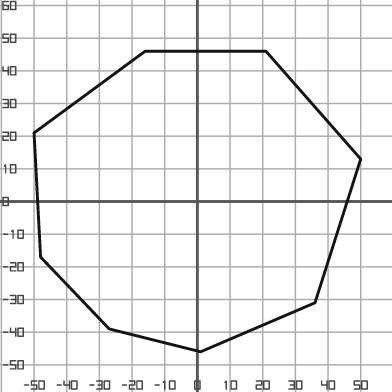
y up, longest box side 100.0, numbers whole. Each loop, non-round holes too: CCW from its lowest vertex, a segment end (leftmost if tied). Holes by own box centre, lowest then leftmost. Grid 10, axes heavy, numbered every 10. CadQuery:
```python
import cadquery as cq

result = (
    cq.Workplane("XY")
    .moveTo(1.0, -46.0)
    .lineTo(36.0, -31.0)
    .lineTo(50.0, 13.0)
    .lineTo(21.0, 46.0)
    .lineTo(-16.0, 46.0)
    .lineTo(-50.0, 21.0)
    .lineTo(-48.0, -17.0)
    .lineTo(-27.0, -39.0)
    .close()
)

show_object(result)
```